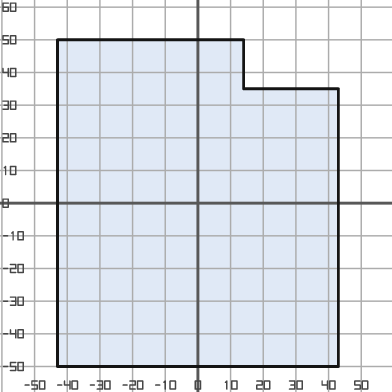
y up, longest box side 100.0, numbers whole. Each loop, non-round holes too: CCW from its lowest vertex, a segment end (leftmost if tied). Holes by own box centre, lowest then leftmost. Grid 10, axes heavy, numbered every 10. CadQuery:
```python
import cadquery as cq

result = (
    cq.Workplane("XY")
    .moveTo(-43.0, -50.0)
    .lineTo(43.0, -50.0)
    .lineTo(43.0, 35.0)
    .lineTo(14.0, 35.0)
    .lineTo(14.0, 50.0)
    .lineTo(-43.0, 50.0)
    .close()
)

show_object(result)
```